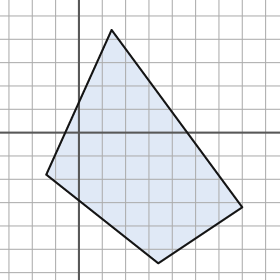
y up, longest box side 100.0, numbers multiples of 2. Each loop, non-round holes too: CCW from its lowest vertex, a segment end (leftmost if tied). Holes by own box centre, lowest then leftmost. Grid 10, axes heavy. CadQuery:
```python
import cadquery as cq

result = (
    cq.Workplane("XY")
    .moveTo(34.0, -56.0)
    .lineTo(70.0, -32.0)
    .lineTo(14.0, 44.0)
    .lineTo(-14.0, -18.0)
    .close()
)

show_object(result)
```